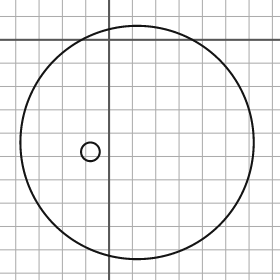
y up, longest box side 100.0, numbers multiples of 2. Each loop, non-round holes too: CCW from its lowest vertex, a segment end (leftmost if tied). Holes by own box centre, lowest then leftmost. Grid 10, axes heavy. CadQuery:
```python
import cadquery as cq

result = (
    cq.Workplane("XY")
    .moveTo(12.0, -44.0)
    .circle(50.0)
    .moveTo(-8.0, -48.0)
    .circle(4.0)
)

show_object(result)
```